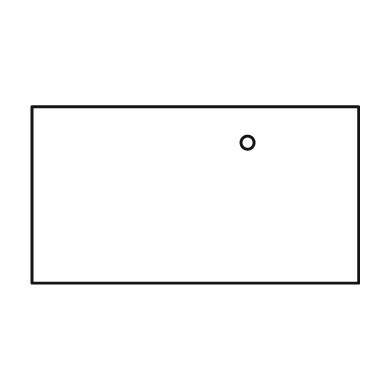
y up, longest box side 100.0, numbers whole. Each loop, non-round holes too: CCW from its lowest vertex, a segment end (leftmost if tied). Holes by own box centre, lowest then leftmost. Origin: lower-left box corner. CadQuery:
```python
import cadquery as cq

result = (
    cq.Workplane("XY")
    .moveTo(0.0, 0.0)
    .lineTo(100.0, 0.0)
    .lineTo(100.0, 54.0)
    .lineTo(0.0, 54.0)
    .close()
    .moveTo(66.0, 43.0)
    .circle(2.0)
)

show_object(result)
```